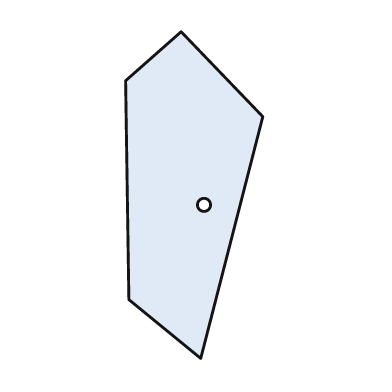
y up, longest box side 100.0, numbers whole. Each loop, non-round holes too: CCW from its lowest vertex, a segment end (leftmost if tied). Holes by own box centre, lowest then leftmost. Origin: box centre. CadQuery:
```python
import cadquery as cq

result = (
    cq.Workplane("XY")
    .moveTo(2.0, -50.0)
    .lineTo(21.0, 24.0)
    .lineTo(-4.0, 50.0)
    .lineTo(-21.0, 35.0)
    .lineTo(-20.0, -32.0)
    .close()
    .moveTo(3.0, -3.0)
    .circle(2.0)
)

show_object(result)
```